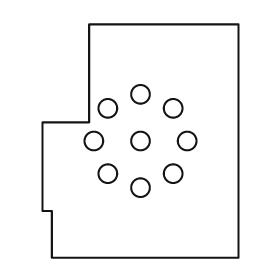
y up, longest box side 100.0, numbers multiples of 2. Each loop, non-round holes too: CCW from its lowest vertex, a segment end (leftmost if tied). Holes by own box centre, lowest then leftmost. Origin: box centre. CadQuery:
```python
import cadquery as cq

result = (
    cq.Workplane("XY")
    .moveTo(-38.0, -50.0)
    .lineTo(42.0, -50.0)
    .lineTo(42.0, 50.0)
    .lineTo(-22.0, 50.0)
    .lineTo(-22.0, 8.0)
    .lineTo(-42.0, 8.0)
    .lineTo(-42.0, -30.0)
    .lineTo(-38.0, -30.0)
    .close()
    .moveTo(0.0, -20.0)
    .circle(4.0)
    .moveTo(-14.0, -14.0)
    .circle(4.0)
    .moveTo(14.0, -14.0)
    .circle(4.0)
    .moveTo(-20.0, 0.0)
    .circle(4.0)
    .moveTo(0.0, 0.0)
    .circle(4.0)
    .moveTo(20.0, 0.0)
    .circle(4.0)
    .moveTo(-14.0, 14.0)
    .circle(4.0)
    .moveTo(14.0, 14.0)
    .circle(4.0)
    .moveTo(0.0, 20.0)
    .circle(4.0)
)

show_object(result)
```